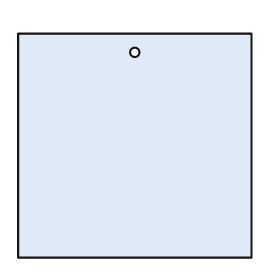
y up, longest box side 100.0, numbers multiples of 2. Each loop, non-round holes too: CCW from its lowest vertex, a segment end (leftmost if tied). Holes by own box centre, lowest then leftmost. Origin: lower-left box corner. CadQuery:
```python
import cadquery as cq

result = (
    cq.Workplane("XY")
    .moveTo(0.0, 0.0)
    .lineTo(100.0, 0.0)
    .lineTo(100.0, 96.0)
    .lineTo(0.0, 96.0)
    .close()
    .moveTo(50.0, 88.0)
    .circle(2.0)
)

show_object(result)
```